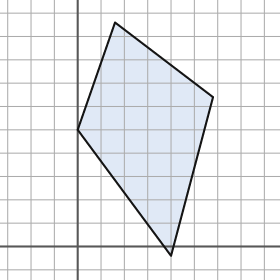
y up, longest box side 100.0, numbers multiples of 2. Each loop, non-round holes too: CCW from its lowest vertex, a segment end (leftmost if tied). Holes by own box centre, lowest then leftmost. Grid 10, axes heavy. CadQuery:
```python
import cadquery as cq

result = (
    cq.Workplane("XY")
    .moveTo(40.0, -4.0)
    .lineTo(58.0, 64.0)
    .lineTo(16.0, 96.0)
    .lineTo(0.0, 50.0)
    .close()
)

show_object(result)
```